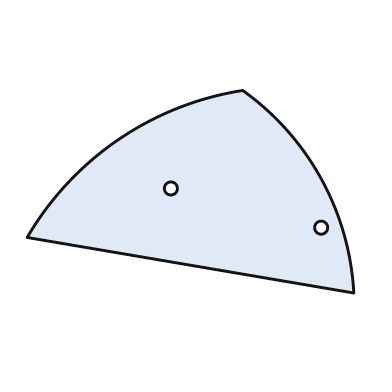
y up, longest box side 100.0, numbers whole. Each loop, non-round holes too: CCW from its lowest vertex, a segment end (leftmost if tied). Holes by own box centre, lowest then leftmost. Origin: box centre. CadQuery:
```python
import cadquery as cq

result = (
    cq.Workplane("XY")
    .moveTo(50.0, -31.0)
    .threePointArc((40.0, 4.0), (16.0, 31.0))
    .threePointArc((-22.0, 16.0), (-50.0, -14.0))
    .close()
    .moveTo(40.0, -11.0)
    .circle(2.0)
    .moveTo(-6.0, 1.0)
    .circle(2.0)
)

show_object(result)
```